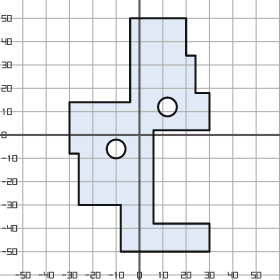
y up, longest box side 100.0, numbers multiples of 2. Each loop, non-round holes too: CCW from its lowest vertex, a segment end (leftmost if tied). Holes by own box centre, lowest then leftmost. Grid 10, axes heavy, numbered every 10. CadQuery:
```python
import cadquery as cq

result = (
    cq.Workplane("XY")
    .moveTo(-8.0, -50.0)
    .lineTo(30.0, -50.0)
    .lineTo(30.0, -38.0)
    .lineTo(6.0, -38.0)
    .lineTo(6.0, 2.0)
    .lineTo(30.0, 2.0)
    .lineTo(30.0, 18.0)
    .lineTo(24.0, 18.0)
    .lineTo(24.0, 34.0)
    .lineTo(20.0, 34.0)
    .lineTo(20.0, 50.0)
    .lineTo(-4.0, 50.0)
    .lineTo(-4.0, 14.0)
    .lineTo(-30.0, 14.0)
    .lineTo(-30.0, -8.0)
    .lineTo(-26.0, -8.0)
    .lineTo(-26.0, -30.0)
    .lineTo(-8.0, -30.0)
    .close()
    .moveTo(-10.0, -6.0)
    .circle(4.0)
    .moveTo(12.0, 12.0)
    .circle(4.0)
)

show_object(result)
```